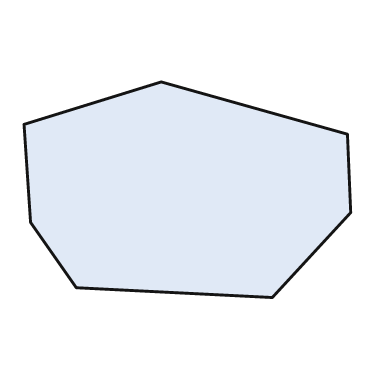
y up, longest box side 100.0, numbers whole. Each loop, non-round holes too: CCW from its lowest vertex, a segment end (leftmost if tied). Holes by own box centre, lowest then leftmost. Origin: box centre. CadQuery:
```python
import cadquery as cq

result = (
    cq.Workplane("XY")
    .moveTo(26.0, -33.0)
    .lineTo(50.0, -7.0)
    .lineTo(49.0, 17.0)
    .lineTo(-8.0, 33.0)
    .lineTo(-50.0, 20.0)
    .lineTo(-48.0, -10.0)
    .lineTo(-34.0, -30.0)
    .close()
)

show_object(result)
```